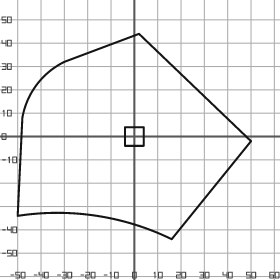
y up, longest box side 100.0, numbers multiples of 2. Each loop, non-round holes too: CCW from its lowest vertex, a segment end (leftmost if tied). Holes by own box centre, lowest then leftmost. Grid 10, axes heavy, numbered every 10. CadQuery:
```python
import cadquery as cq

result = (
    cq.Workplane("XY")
    .moveTo(16.0, -44.0)
    .lineTo(50.0, -2.0)
    .lineTo(2.0, 44.0)
    .lineTo(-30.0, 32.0)
    .threePointArc((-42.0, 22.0), (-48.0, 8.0))
    .lineTo(-50.0, -34.0)
    .threePointArc((-16.0, -34.0), (16.0, -44.0))
    .close()
    .moveTo(-4.0, -4.0)
    .lineTo(4.0, -4.0)
    .lineTo(4.0, 4.0)
    .lineTo(-4.0, 4.0)
    .close()
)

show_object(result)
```